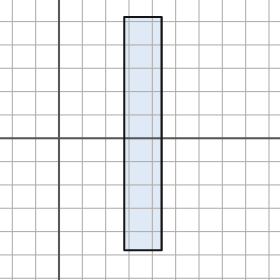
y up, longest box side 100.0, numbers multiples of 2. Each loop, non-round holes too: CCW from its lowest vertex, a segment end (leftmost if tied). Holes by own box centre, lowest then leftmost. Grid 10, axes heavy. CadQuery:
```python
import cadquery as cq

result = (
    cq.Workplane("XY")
    .moveTo(28.0, -48.0)
    .lineTo(44.0, -48.0)
    .lineTo(44.0, 52.0)
    .lineTo(28.0, 52.0)
    .close()
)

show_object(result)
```